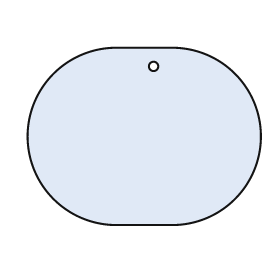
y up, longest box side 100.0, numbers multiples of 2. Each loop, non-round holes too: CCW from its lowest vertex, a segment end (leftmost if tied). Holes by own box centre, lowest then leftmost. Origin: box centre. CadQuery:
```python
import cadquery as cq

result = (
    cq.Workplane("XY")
    .moveTo(-12.0, -38.0)
    .lineTo(12.0, -38.0)
    .threePointArc((50.0, 0.0), (12.0, 38.0))
    .lineTo(-12.0, 38.0)
    .threePointArc((-50.0, 0.0), (-12.0, -38.0))
    .close()
    .moveTo(4.0, 30.0)
    .circle(2.0)
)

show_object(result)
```